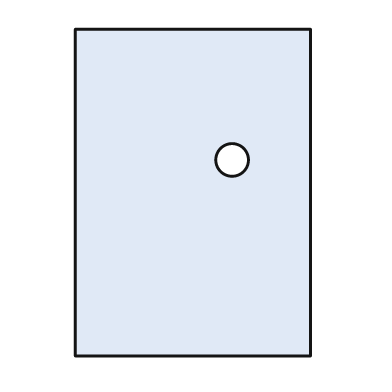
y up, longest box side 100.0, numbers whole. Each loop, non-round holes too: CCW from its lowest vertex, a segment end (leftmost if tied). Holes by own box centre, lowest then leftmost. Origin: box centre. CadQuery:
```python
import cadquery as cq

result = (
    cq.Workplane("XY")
    .moveTo(-36.0, -50.0)
    .lineTo(36.0, -50.0)
    .lineTo(36.0, 50.0)
    .lineTo(-36.0, 50.0)
    .close()
    .moveTo(12.0, 10.0)
    .circle(5.0)
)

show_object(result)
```